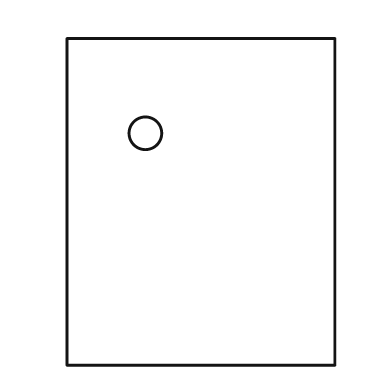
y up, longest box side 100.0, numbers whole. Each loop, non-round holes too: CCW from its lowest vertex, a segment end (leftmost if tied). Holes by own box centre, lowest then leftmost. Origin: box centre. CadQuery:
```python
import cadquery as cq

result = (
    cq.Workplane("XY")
    .moveTo(-41.0, -50.0)
    .lineTo(41.0, -50.0)
    .lineTo(41.0, 50.0)
    .lineTo(-41.0, 50.0)
    .close()
    .moveTo(-17.0, 21.0)
    .circle(5.0)
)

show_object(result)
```